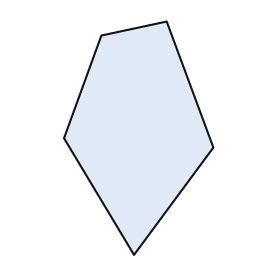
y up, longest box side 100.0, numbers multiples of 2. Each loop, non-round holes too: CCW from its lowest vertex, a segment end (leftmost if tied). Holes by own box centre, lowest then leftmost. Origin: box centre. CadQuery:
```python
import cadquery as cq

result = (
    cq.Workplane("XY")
    .moveTo(-2.0, -50.0)
    .lineTo(32.0, -4.0)
    .lineTo(12.0, 50.0)
    .lineTo(-16.0, 44.0)
    .lineTo(-32.0, 0.0)
    .close()
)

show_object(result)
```